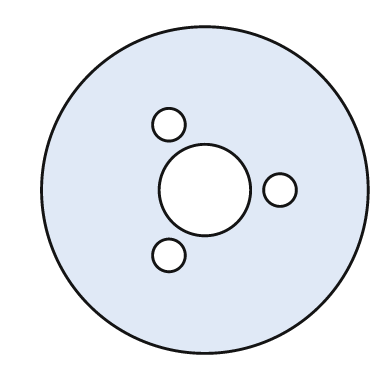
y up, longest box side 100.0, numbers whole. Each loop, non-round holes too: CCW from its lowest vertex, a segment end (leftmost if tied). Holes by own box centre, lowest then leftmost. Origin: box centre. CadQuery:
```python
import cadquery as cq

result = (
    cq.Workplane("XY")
    .moveTo(0.0, 0.0)
    .circle(50.0)
    .moveTo(-11.0, -20.0)
    .circle(5.0)
    .moveTo(0.0, 0.0)
    .circle(14.0)
    .moveTo(23.0, 0.0)
    .circle(5.0)
    .moveTo(-11.0, 20.0)
    .circle(5.0)
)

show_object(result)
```